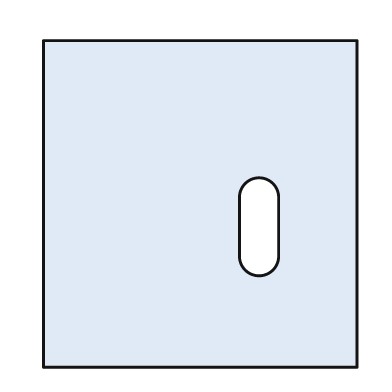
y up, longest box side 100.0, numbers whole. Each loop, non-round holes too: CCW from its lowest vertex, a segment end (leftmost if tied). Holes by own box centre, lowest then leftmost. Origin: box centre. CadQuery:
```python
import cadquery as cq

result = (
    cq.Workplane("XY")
    .moveTo(-48.0, -50.0)
    .lineTo(48.0, -50.0)
    .lineTo(48.0, 50.0)
    .lineTo(-48.0, 50.0)
    .close()
    .moveTo(12.0, -16.0)
    .threePointArc((18.0, -22.0), (24.0, -16.0))
    .lineTo(24.0, 2.0)
    .threePointArc((18.0, 8.0), (12.0, 2.0))
    .close()
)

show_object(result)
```